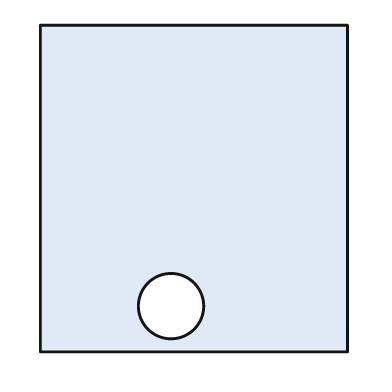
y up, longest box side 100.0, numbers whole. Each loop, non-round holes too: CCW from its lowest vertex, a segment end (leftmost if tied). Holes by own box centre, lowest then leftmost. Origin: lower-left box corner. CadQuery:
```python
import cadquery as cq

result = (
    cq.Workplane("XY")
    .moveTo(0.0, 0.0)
    .lineTo(94.0, 0.0)
    .lineTo(94.0, 100.0)
    .lineTo(0.0, 100.0)
    .close()
    .moveTo(40.0, 14.0)
    .circle(10.0)
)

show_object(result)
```